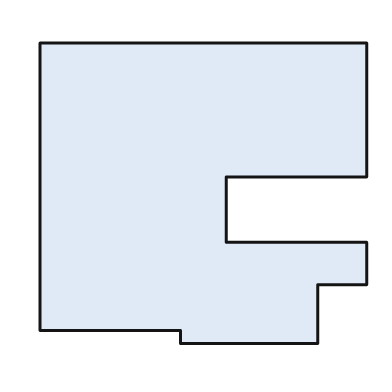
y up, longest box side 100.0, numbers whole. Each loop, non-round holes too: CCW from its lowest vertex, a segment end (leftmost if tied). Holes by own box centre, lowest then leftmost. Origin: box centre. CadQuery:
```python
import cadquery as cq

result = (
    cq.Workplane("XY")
    .moveTo(-7.0, -46.0)
    .lineTo(35.0, -46.0)
    .lineTo(35.0, -28.0)
    .lineTo(50.0, -28.0)
    .lineTo(50.0, -15.0)
    .lineTo(7.0, -15.0)
    .lineTo(7.0, 5.0)
    .lineTo(50.0, 5.0)
    .lineTo(50.0, 46.0)
    .lineTo(-50.0, 46.0)
    .lineTo(-50.0, -42.0)
    .lineTo(-7.0, -42.0)
    .close()
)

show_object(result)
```